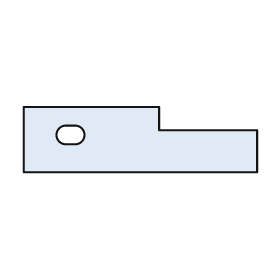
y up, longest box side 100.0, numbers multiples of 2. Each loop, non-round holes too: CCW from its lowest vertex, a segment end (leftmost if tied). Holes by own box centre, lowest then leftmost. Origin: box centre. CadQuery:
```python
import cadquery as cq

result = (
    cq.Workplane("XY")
    .moveTo(-50.0, -14.0)
    .lineTo(50.0, -14.0)
    .lineTo(50.0, 4.0)
    .lineTo(8.0, 4.0)
    .lineTo(8.0, 14.0)
    .lineTo(-50.0, 14.0)
    .close()
    .moveTo(-32.0, -2.0)
    .lineTo(-28.0, -2.0)
    .threePointArc((-24.0, 2.0), (-28.0, 6.0))
    .lineTo(-32.0, 6.0)
    .threePointArc((-36.0, 2.0), (-32.0, -2.0))
    .close()
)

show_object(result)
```